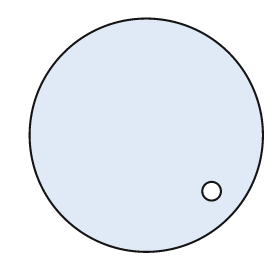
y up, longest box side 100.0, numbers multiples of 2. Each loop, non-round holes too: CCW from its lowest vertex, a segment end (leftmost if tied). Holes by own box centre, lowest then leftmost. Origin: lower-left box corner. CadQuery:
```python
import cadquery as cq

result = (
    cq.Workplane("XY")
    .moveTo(50.0, 50.0)
    .circle(50.0)
    .moveTo(78.0, 26.0)
    .circle(4.0)
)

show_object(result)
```